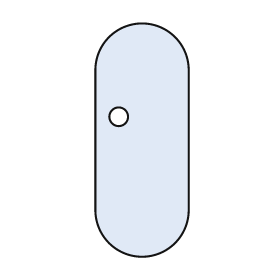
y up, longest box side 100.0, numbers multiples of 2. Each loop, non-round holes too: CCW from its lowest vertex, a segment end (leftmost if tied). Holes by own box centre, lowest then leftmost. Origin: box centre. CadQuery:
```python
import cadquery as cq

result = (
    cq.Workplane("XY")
    .moveTo(-20.0, -30.0)
    .threePointArc((0.0, -50.0), (20.0, -30.0))
    .lineTo(20.0, 30.0)
    .threePointArc((0.0, 50.0), (-20.0, 30.0))
    .close()
    .moveTo(-10.0, 10.0)
    .circle(4.0)
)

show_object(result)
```